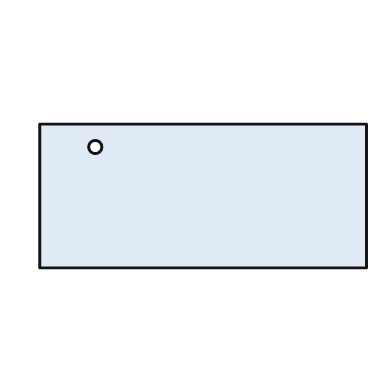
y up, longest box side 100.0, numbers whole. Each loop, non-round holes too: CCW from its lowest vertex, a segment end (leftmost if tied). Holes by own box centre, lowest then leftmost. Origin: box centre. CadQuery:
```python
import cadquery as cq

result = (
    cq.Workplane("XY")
    .moveTo(-50.0, -22.0)
    .lineTo(50.0, -22.0)
    .lineTo(50.0, 22.0)
    .lineTo(-50.0, 22.0)
    .close()
    .moveTo(-33.0, 15.0)
    .circle(2.0)
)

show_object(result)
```